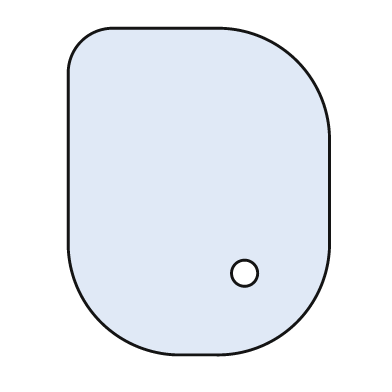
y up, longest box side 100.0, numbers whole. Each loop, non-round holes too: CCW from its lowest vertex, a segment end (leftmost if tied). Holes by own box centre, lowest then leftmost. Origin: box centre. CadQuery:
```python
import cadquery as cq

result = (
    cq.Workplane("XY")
    .moveTo(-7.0, -50.0)
    .lineTo(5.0, -50.0)
    .threePointArc((30.0, -40.0), (40.0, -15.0))
    .lineTo(40.0, 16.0)
    .threePointArc((30.0, 40.0), (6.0, 50.0))
    .lineTo(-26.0, 50.0)
    .threePointArc((-36.0, 46.0), (-40.0, 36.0))
    .lineTo(-40.0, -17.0)
    .threePointArc((-30.0, -40.0), (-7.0, -50.0))
    .close()
    .moveTo(14.0, -25.0)
    .circle(4.0)
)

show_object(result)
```